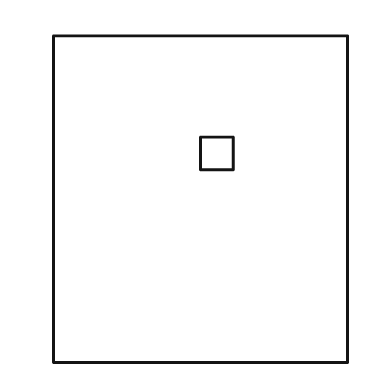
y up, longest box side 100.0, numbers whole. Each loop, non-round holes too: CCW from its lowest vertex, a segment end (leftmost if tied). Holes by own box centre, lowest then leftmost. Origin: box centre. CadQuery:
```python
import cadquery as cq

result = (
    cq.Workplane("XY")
    .moveTo(-45.0, -50.0)
    .lineTo(45.0, -50.0)
    .lineTo(45.0, 50.0)
    .lineTo(-45.0, 50.0)
    .close()
    .moveTo(0.0, 9.0)
    .lineTo(10.0, 9.0)
    .lineTo(10.0, 19.0)
    .lineTo(0.0, 19.0)
    .close()
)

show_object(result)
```